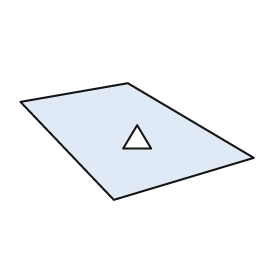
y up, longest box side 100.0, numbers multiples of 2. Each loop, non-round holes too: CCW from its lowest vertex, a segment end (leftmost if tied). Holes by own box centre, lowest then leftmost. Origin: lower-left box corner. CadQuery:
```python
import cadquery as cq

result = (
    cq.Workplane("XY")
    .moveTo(40.0, 0.0)
    .lineTo(100.0, 18.0)
    .lineTo(46.0, 50.0)
    .lineTo(0.0, 42.0)
    .close()
    .moveTo(44.0, 22.0)
    .lineTo(56.0, 22.0)
    .lineTo(50.0, 32.0)
    .close()
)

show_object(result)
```